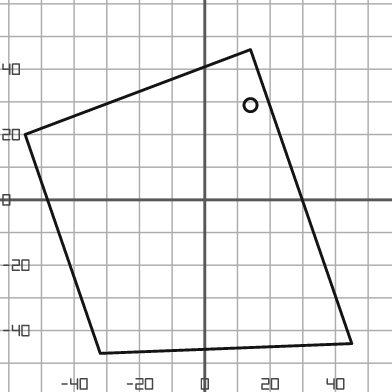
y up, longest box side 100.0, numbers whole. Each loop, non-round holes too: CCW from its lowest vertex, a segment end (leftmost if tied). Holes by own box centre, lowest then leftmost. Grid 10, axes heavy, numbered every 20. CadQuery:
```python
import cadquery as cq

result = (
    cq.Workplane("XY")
    .moveTo(-32.0, -47.0)
    .lineTo(45.0, -44.0)
    .lineTo(14.0, 46.0)
    .lineTo(-55.0, 20.0)
    .close()
    .moveTo(14.0, 29.0)
    .circle(2.0)
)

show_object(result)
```